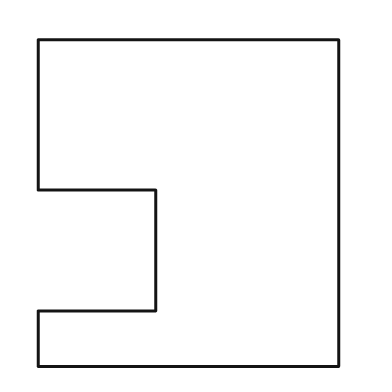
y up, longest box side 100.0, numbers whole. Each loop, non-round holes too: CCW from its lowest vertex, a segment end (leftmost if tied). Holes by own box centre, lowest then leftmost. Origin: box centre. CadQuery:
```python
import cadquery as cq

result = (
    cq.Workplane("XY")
    .moveTo(-46.0, -50.0)
    .lineTo(46.0, -50.0)
    .lineTo(46.0, 50.0)
    .lineTo(-46.0, 50.0)
    .lineTo(-46.0, 4.0)
    .lineTo(-10.0, 4.0)
    .lineTo(-10.0, -33.0)
    .lineTo(-46.0, -33.0)
    .close()
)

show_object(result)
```